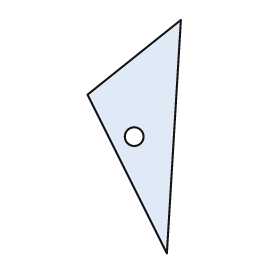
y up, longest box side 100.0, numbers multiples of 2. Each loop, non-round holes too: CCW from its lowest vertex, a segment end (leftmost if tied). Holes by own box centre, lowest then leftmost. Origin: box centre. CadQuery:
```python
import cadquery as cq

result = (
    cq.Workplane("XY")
    .moveTo(14.0, -50.0)
    .lineTo(20.0, 50.0)
    .lineTo(-20.0, 18.0)
    .close()
    .moveTo(0.0, 0.0)
    .circle(4.0)
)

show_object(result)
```